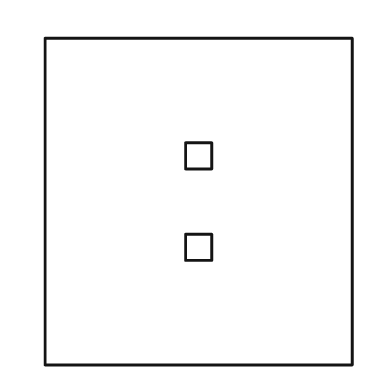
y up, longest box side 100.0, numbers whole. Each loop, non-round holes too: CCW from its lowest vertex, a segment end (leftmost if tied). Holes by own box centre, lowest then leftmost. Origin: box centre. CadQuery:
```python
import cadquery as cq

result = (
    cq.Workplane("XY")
    .moveTo(-47.0, -50.0)
    .lineTo(47.0, -50.0)
    .lineTo(47.0, 50.0)
    .lineTo(-47.0, 50.0)
    .close()
    .moveTo(-4.0, -18.0)
    .lineTo(4.0, -18.0)
    .lineTo(4.0, -10.0)
    .lineTo(-4.0, -10.0)
    .close()
    .moveTo(-4.0, 10.0)
    .lineTo(4.0, 10.0)
    .lineTo(4.0, 18.0)
    .lineTo(-4.0, 18.0)
    .close()
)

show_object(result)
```